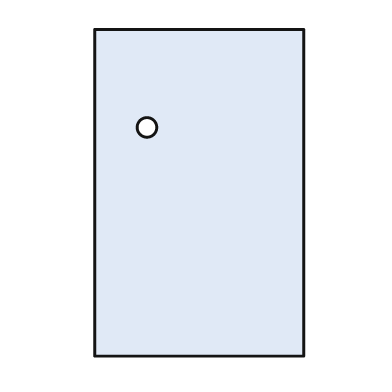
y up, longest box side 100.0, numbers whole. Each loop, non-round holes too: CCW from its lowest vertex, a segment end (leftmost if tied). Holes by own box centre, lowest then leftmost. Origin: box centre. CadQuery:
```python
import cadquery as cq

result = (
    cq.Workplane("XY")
    .moveTo(-32.0, -50.0)
    .lineTo(32.0, -50.0)
    .lineTo(32.0, 50.0)
    .lineTo(-32.0, 50.0)
    .close()
    .moveTo(-16.0, 20.0)
    .circle(3.0)
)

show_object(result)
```